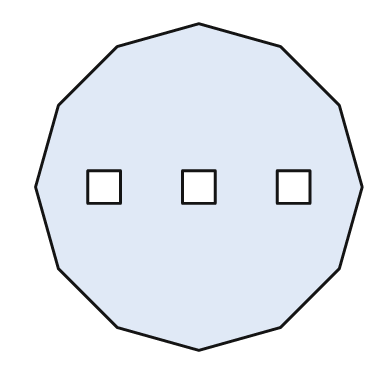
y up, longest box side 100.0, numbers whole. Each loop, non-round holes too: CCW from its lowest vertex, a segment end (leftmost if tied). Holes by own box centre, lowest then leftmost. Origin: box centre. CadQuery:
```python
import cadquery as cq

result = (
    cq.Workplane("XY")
    .moveTo(0.0, -50.0)
    .lineTo(25.0, -43.0)
    .lineTo(43.0, -25.0)
    .lineTo(50.0, 0.0)
    .lineTo(43.0, 25.0)
    .lineTo(25.0, 43.0)
    .lineTo(0.0, 50.0)
    .lineTo(-25.0, 43.0)
    .lineTo(-43.0, 25.0)
    .lineTo(-50.0, 0.0)
    .lineTo(-43.0, -25.0)
    .lineTo(-25.0, -43.0)
    .close()
    .moveTo(-34.0, -5.0)
    .lineTo(-24.0, -5.0)
    .lineTo(-24.0, 5.0)
    .lineTo(-34.0, 5.0)
    .close()
    .moveTo(-5.0, -5.0)
    .lineTo(5.0, -5.0)
    .lineTo(5.0, 5.0)
    .lineTo(-5.0, 5.0)
    .close()
    .moveTo(24.0, -5.0)
    .lineTo(34.0, -5.0)
    .lineTo(34.0, 5.0)
    .lineTo(24.0, 5.0)
    .close()
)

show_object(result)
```